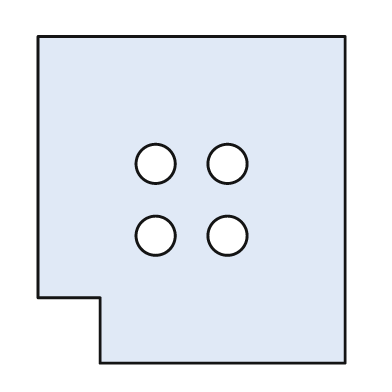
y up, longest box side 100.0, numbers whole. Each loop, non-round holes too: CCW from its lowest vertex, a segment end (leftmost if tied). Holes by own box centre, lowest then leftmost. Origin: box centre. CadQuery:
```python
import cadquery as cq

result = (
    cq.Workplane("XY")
    .moveTo(-28.0, -50.0)
    .lineTo(47.0, -50.0)
    .lineTo(47.0, 50.0)
    .lineTo(-47.0, 50.0)
    .lineTo(-47.0, -30.0)
    .lineTo(-28.0, -30.0)
    .close()
    .moveTo(-11.0, -11.0)
    .circle(6.0)
    .moveTo(11.0, -11.0)
    .circle(6.0)
    .moveTo(-11.0, 11.0)
    .circle(6.0)
    .moveTo(11.0, 11.0)
    .circle(6.0)
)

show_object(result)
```